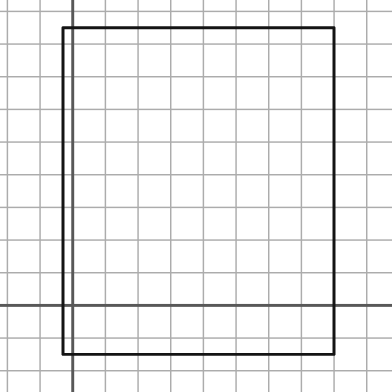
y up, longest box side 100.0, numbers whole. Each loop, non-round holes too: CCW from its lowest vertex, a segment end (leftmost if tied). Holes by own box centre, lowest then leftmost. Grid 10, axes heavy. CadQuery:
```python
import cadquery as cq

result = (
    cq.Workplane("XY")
    .moveTo(-3.0, -15.0)
    .lineTo(80.0, -15.0)
    .lineTo(80.0, 85.0)
    .lineTo(-3.0, 85.0)
    .close()
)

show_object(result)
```